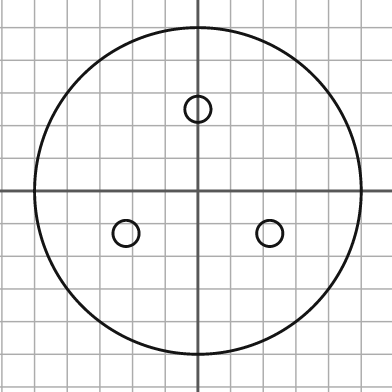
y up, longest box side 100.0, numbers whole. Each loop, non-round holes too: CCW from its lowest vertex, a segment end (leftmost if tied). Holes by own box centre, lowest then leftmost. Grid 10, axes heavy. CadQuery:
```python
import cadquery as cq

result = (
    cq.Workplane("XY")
    .moveTo(0.0, 0.0)
    .circle(50.0)
    .moveTo(-22.0, -13.0)
    .circle(4.0)
    .moveTo(22.0, -13.0)
    .circle(4.0)
    .moveTo(0.0, 25.0)
    .circle(4.0)
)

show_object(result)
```